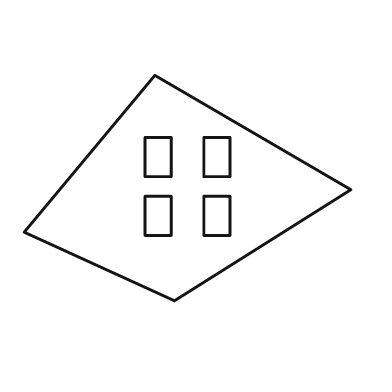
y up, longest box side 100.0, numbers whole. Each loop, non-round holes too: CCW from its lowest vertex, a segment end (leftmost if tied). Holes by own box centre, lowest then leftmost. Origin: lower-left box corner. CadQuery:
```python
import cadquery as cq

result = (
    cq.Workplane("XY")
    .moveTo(46.0, 0.0)
    .lineTo(100.0, 34.0)
    .lineTo(40.0, 69.0)
    .lineTo(0.0, 21.0)
    .close()
    .moveTo(37.0, 20.0)
    .lineTo(45.0, 20.0)
    .lineTo(45.0, 32.0)
    .lineTo(37.0, 32.0)
    .close()
    .moveTo(55.0, 20.0)
    .lineTo(63.0, 20.0)
    .lineTo(63.0, 32.0)
    .lineTo(55.0, 32.0)
    .close()
    .moveTo(37.0, 38.0)
    .lineTo(45.0, 38.0)
    .lineTo(45.0, 50.0)
    .lineTo(37.0, 50.0)
    .close()
    .moveTo(55.0, 38.0)
    .lineTo(63.0, 38.0)
    .lineTo(63.0, 50.0)
    .lineTo(55.0, 50.0)
    .close()
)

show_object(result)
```